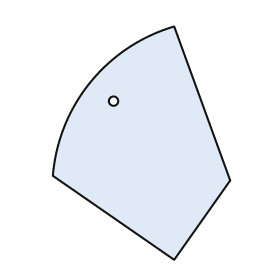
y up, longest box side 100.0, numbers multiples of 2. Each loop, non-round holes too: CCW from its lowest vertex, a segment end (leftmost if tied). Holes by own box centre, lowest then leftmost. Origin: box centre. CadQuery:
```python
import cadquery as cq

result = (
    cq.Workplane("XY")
    .moveTo(14.0, -50.0)
    .lineTo(38.0, -16.0)
    .lineTo(14.0, 50.0)
    .threePointArc((-22.0, 26.0), (-38.0, -14.0))
    .close()
    .moveTo(-12.0, 18.0)
    .circle(2.0)
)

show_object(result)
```